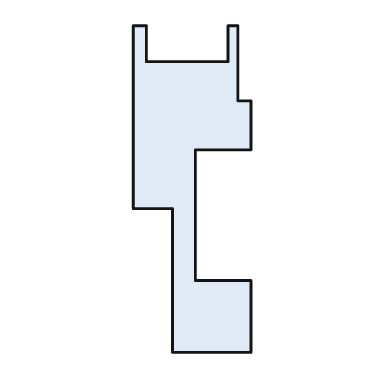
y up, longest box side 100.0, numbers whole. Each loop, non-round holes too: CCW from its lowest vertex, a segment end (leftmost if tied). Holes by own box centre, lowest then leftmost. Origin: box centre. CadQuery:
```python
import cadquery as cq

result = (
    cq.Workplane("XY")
    .moveTo(-6.0, -50.0)
    .lineTo(18.0, -50.0)
    .lineTo(18.0, -28.0)
    .lineTo(1.0, -28.0)
    .lineTo(1.0, 12.0)
    .lineTo(18.0, 12.0)
    .lineTo(18.0, 27.0)
    .lineTo(14.0, 27.0)
    .lineTo(14.0, 50.0)
    .lineTo(11.0, 50.0)
    .lineTo(11.0, 39.0)
    .lineTo(-14.0, 39.0)
    .lineTo(-14.0, 50.0)
    .lineTo(-18.0, 50.0)
    .lineTo(-18.0, -6.0)
    .lineTo(-6.0, -6.0)
    .close()
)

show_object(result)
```